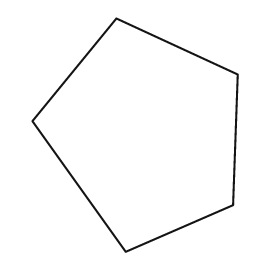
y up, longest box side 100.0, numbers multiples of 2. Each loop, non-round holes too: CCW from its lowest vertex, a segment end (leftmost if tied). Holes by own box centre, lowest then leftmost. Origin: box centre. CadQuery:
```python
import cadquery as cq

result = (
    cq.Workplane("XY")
    .moveTo(-4.0, -50.0)
    .lineTo(42.0, -30.0)
    .lineTo(44.0, 26.0)
    .lineTo(-8.0, 50.0)
    .lineTo(-44.0, 6.0)
    .close()
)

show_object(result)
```